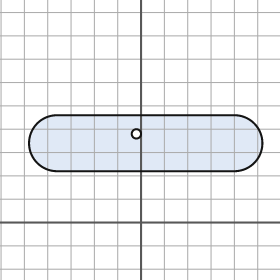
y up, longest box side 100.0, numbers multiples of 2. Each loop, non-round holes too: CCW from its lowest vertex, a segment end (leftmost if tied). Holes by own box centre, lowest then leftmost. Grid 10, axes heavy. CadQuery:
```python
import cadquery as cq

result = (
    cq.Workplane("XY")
    .moveTo(-36.0, 22.0)
    .lineTo(40.0, 22.0)
    .threePointArc((52.0, 34.0), (40.0, 46.0))
    .lineTo(-36.0, 46.0)
    .threePointArc((-48.0, 34.0), (-36.0, 22.0))
    .close()
    .moveTo(-2.0, 38.0)
    .circle(2.0)
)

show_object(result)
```